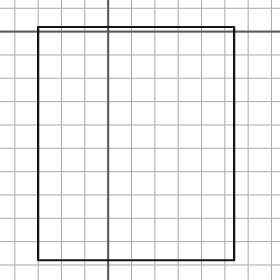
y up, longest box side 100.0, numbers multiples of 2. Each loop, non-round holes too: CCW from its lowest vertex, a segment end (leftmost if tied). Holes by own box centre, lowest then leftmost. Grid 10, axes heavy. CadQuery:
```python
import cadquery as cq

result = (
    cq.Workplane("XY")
    .moveTo(-30.0, -98.0)
    .lineTo(54.0, -98.0)
    .lineTo(54.0, 2.0)
    .lineTo(-30.0, 2.0)
    .close()
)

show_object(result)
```